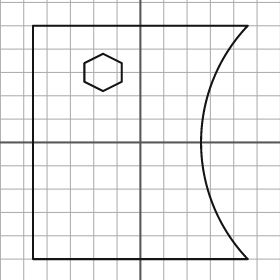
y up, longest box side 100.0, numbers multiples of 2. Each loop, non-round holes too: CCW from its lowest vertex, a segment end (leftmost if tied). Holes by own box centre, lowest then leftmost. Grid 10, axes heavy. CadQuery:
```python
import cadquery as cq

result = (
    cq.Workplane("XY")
    .moveTo(-46.0, -50.0)
    .lineTo(46.0, -50.0)
    .threePointArc((26.0, 0.0), (46.0, 50.0))
    .lineTo(-46.0, 50.0)
    .close()
    .moveTo(-16.0, 22.0)
    .lineTo(-8.0, 26.0)
    .lineTo(-8.0, 34.0)
    .lineTo(-16.0, 38.0)
    .lineTo(-24.0, 34.0)
    .lineTo(-24.0, 26.0)
    .close()
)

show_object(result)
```